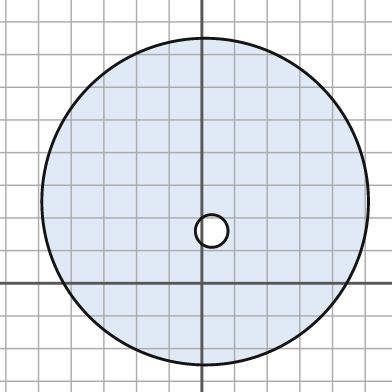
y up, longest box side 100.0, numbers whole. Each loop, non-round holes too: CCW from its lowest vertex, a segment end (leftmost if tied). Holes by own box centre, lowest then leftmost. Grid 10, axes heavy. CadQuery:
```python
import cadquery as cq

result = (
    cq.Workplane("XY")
    .moveTo(1.0, 25.0)
    .circle(50.0)
    .moveTo(3.0, 16.0)
    .circle(5.0)
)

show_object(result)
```